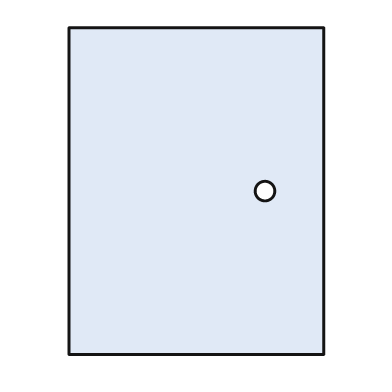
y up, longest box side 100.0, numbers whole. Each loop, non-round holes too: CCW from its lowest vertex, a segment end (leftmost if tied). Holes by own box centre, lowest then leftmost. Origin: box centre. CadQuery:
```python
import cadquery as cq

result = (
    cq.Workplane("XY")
    .moveTo(-39.0, -50.0)
    .lineTo(39.0, -50.0)
    .lineTo(39.0, 50.0)
    .lineTo(-39.0, 50.0)
    .close()
    .moveTo(21.0, 0.0)
    .circle(3.0)
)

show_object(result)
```